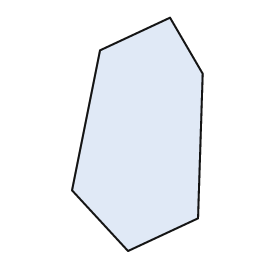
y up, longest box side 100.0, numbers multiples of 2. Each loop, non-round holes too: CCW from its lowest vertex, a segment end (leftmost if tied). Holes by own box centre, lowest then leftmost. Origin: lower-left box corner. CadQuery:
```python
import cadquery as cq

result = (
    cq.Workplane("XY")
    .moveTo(24.0, 0.0)
    .lineTo(54.0, 14.0)
    .lineTo(56.0, 76.0)
    .lineTo(42.0, 100.0)
    .lineTo(12.0, 86.0)
    .lineTo(0.0, 26.0)
    .close()
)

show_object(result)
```